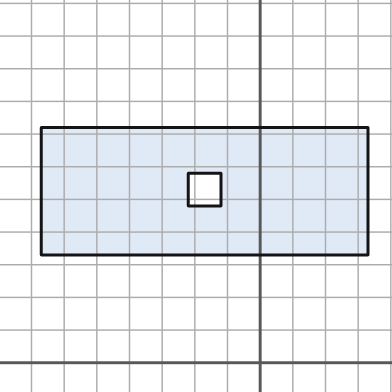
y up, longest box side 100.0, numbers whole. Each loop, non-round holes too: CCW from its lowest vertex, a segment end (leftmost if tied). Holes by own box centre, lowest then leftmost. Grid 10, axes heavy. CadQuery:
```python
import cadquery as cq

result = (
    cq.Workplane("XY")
    .moveTo(-67.0, 33.0)
    .lineTo(33.0, 33.0)
    .lineTo(33.0, 72.0)
    .lineTo(-67.0, 72.0)
    .close()
    .moveTo(-22.0, 48.0)
    .lineTo(-12.0, 48.0)
    .lineTo(-12.0, 58.0)
    .lineTo(-22.0, 58.0)
    .close()
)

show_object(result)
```